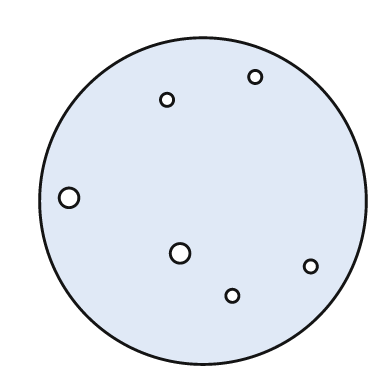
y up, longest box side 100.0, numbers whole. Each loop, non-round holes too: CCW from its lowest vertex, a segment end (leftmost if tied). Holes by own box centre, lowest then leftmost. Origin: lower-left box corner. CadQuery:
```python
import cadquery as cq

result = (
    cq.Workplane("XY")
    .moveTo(50.0, 50.0)
    .circle(50.0)
    .moveTo(59.0, 21.0)
    .circle(2.0)
    .moveTo(83.0, 30.0)
    .circle(2.0)
    .moveTo(43.0, 34.0)
    .circle(3.0)
    .moveTo(9.0, 51.0)
    .circle(3.0)
    .moveTo(39.0, 81.0)
    .circle(2.0)
    .moveTo(66.0, 88.0)
    .circle(2.0)
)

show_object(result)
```